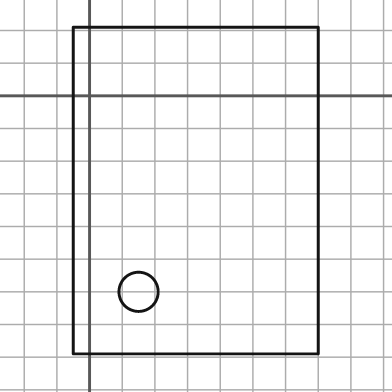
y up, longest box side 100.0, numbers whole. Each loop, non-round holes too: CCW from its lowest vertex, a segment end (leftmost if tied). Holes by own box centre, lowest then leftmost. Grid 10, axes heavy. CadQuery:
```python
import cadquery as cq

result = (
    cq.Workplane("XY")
    .moveTo(-5.0, -79.0)
    .lineTo(70.0, -79.0)
    .lineTo(70.0, 21.0)
    .lineTo(-5.0, 21.0)
    .close()
    .moveTo(15.0, -60.0)
    .circle(6.0)
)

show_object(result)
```